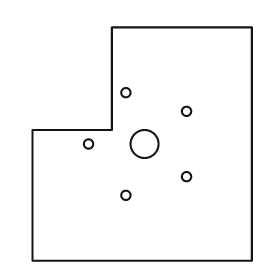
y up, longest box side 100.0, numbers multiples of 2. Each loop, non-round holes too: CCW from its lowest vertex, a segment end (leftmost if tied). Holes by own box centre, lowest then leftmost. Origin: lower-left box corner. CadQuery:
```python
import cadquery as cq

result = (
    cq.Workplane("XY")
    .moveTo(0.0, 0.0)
    .lineTo(94.0, 0.0)
    .lineTo(94.0, 100.0)
    .lineTo(34.0, 100.0)
    .lineTo(34.0, 56.0)
    .lineTo(0.0, 56.0)
    .close()
    .moveTo(40.0, 28.0)
    .circle(2.0)
    .moveTo(66.0, 36.0)
    .circle(2.0)
    .moveTo(24.0, 50.0)
    .circle(2.0)
    .moveTo(48.0, 50.0)
    .circle(6.0)
    .moveTo(66.0, 64.0)
    .circle(2.0)
    .moveTo(40.0, 72.0)
    .circle(2.0)
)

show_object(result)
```